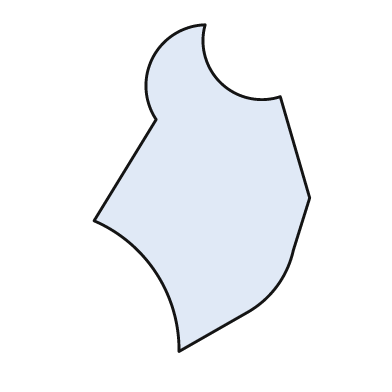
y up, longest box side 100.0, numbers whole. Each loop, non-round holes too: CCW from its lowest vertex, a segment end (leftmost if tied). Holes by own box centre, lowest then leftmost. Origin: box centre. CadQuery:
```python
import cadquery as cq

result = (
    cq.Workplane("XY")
    .moveTo(-7.0, -50.0)
    .lineTo(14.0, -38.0)
    .threePointArc((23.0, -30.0), (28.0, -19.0))
    .lineTo(33.0, -3.0)
    .lineTo(24.0, 28.0)
    .threePointArc((6.0, 32.0), (1.0, 50.0))
    .threePointArc((-15.0, 40.0), (-14.0, 21.0))
    .lineTo(-33.0, -10.0)
    .threePointArc((-14.0, -26.0), (-7.0, -50.0))
    .close()
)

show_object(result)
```